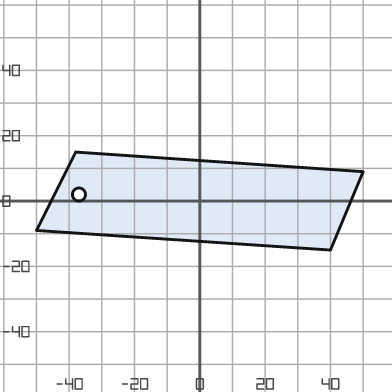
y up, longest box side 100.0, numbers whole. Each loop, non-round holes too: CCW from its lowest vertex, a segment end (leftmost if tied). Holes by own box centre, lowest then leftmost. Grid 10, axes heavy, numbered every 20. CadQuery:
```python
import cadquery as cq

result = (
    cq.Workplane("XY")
    .moveTo(40.0, -15.0)
    .lineTo(50.0, 9.0)
    .lineTo(-38.0, 15.0)
    .lineTo(-50.0, -9.0)
    .close()
    .moveTo(-37.0, 2.0)
    .circle(2.0)
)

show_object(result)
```